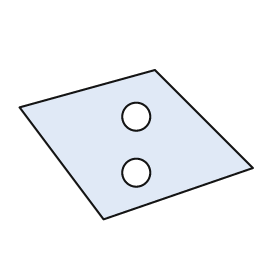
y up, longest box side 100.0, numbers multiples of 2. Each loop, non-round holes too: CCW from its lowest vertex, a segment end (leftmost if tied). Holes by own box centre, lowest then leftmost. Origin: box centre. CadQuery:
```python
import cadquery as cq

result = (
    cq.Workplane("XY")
    .moveTo(-14.0, -32.0)
    .lineTo(50.0, -10.0)
    .lineTo(8.0, 32.0)
    .lineTo(-50.0, 16.0)
    .close()
    .moveTo(0.0, -12.0)
    .circle(6.0)
    .moveTo(0.0, 12.0)
    .circle(6.0)
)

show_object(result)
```